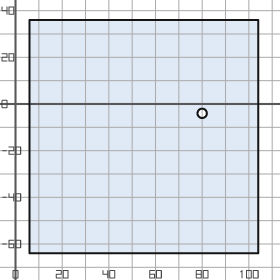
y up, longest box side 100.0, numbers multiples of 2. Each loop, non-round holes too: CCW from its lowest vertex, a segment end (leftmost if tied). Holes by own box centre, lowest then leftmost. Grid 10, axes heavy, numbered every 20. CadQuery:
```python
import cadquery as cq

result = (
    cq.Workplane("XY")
    .moveTo(6.0, -64.0)
    .lineTo(104.0, -64.0)
    .lineTo(104.0, 36.0)
    .lineTo(6.0, 36.0)
    .close()
    .moveTo(80.0, -4.0)
    .circle(2.0)
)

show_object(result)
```